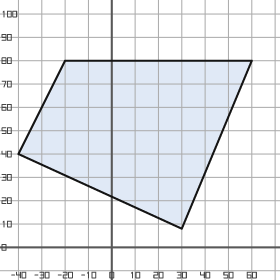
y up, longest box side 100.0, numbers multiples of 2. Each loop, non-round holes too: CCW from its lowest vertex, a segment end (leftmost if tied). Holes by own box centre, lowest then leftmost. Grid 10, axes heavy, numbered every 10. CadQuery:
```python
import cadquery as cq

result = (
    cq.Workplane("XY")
    .moveTo(30.0, 8.0)
    .lineTo(60.0, 80.0)
    .lineTo(-20.0, 80.0)
    .lineTo(-40.0, 40.0)
    .close()
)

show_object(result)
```